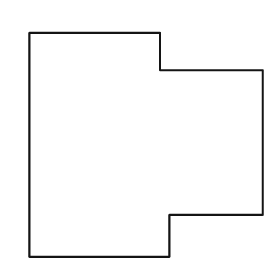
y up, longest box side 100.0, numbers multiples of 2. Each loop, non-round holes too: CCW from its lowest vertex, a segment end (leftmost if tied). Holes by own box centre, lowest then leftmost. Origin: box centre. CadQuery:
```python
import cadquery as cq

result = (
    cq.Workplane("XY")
    .moveTo(-50.0, -48.0)
    .lineTo(10.0, -48.0)
    .lineTo(10.0, -30.0)
    .lineTo(50.0, -30.0)
    .lineTo(50.0, 32.0)
    .lineTo(6.0, 32.0)
    .lineTo(6.0, 48.0)
    .lineTo(-50.0, 48.0)
    .close()
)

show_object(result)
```